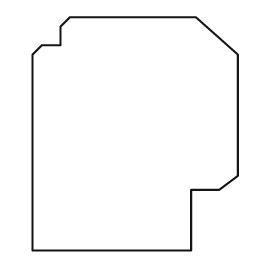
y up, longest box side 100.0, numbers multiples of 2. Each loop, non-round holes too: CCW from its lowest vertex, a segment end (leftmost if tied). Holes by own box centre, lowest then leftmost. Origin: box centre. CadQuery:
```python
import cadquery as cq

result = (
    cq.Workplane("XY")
    .moveTo(-44.0, -50.0)
    .lineTo(24.0, -50.0)
    .lineTo(24.0, -24.0)
    .lineTo(36.0, -24.0)
    .lineTo(44.0, -18.0)
    .lineTo(44.0, 34.0)
    .lineTo(26.0, 50.0)
    .lineTo(-28.0, 50.0)
    .lineTo(-32.0, 46.0)
    .lineTo(-32.0, 38.0)
    .lineTo(-40.0, 38.0)
    .lineTo(-44.0, 34.0)
    .close()
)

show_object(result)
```